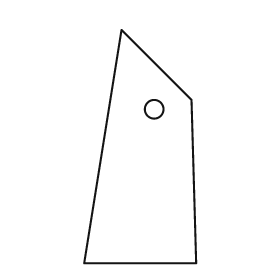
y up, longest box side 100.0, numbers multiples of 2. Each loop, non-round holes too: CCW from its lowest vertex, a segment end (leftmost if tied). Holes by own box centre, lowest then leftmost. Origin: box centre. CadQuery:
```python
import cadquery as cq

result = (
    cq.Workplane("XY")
    .moveTo(-24.0, -50.0)
    .lineTo(24.0, -50.0)
    .lineTo(22.0, 20.0)
    .lineTo(-8.0, 50.0)
    .close()
    .moveTo(6.0, 16.0)
    .circle(4.0)
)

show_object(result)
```